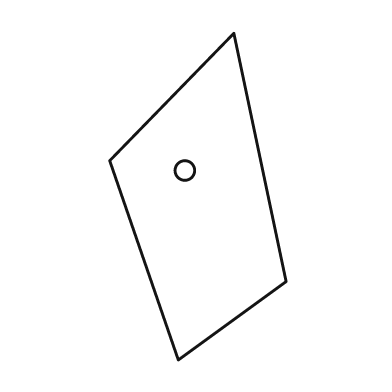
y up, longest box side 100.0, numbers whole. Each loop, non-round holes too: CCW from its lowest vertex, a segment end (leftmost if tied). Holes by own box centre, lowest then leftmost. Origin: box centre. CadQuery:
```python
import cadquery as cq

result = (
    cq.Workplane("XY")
    .moveTo(-6.0, -50.0)
    .lineTo(27.0, -26.0)
    .lineTo(11.0, 50.0)
    .lineTo(-27.0, 11.0)
    .close()
    .moveTo(-4.0, 8.0)
    .circle(3.0)
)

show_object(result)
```